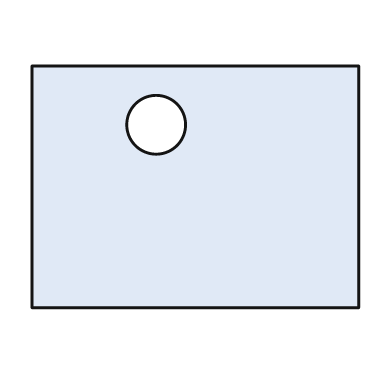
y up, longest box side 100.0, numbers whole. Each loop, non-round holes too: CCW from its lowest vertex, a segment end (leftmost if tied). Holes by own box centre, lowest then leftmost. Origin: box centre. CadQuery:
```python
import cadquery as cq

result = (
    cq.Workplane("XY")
    .moveTo(-50.0, -37.0)
    .lineTo(50.0, -37.0)
    .lineTo(50.0, 37.0)
    .lineTo(-50.0, 37.0)
    .close()
    .moveTo(-12.0, 19.0)
    .circle(9.0)
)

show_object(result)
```